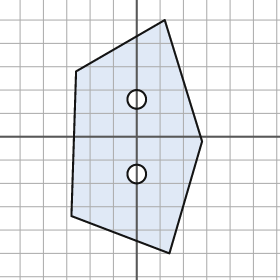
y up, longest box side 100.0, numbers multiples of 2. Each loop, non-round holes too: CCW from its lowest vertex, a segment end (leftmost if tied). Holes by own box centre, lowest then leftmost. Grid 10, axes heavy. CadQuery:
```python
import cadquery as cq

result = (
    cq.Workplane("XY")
    .moveTo(14.0, -50.0)
    .lineTo(28.0, -2.0)
    .lineTo(12.0, 50.0)
    .lineTo(-26.0, 28.0)
    .lineTo(-28.0, -34.0)
    .close()
    .moveTo(0.0, -16.0)
    .circle(4.0)
    .moveTo(0.0, 16.0)
    .circle(4.0)
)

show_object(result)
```